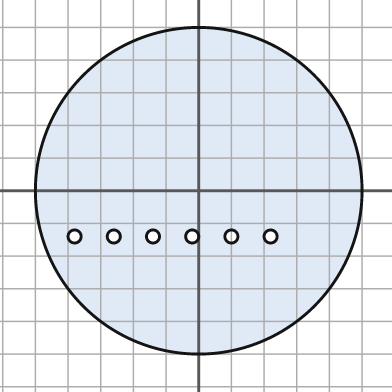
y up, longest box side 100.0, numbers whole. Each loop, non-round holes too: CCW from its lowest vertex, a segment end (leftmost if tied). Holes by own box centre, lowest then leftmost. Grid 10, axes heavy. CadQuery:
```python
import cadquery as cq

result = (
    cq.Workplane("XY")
    .moveTo(0.0, 0.0)
    .circle(50.0)
    .moveTo(-38.0, -14.0)
    .circle(2.0)
    .moveTo(-26.0, -14.0)
    .circle(2.0)
    .moveTo(-14.0, -14.0)
    .circle(2.0)
    .moveTo(-2.0, -14.0)
    .circle(2.0)
    .moveTo(10.0, -14.0)
    .circle(2.0)
    .moveTo(22.0, -14.0)
    .circle(2.0)
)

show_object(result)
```